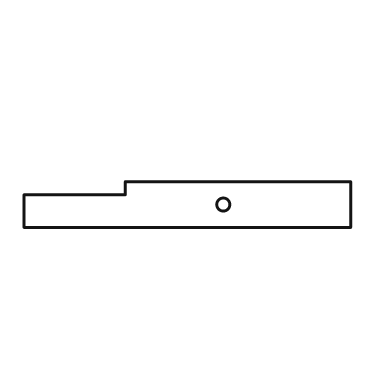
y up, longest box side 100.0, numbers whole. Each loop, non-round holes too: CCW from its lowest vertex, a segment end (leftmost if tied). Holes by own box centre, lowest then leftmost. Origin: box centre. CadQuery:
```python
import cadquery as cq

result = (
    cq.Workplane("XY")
    .moveTo(-50.0, -7.0)
    .lineTo(50.0, -7.0)
    .lineTo(50.0, 7.0)
    .lineTo(-19.0, 7.0)
    .lineTo(-19.0, 3.0)
    .lineTo(-50.0, 3.0)
    .close()
    .moveTo(11.0, 0.0)
    .circle(2.0)
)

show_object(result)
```